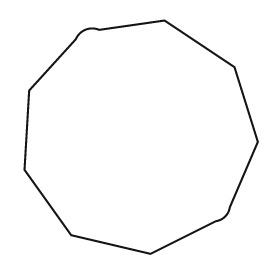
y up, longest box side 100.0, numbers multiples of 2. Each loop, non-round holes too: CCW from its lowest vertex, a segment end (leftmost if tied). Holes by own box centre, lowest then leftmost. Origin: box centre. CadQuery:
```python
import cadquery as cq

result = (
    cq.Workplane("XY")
    .moveTo(4.0, -50.0)
    .lineTo(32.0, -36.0)
    .threePointArc((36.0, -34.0), (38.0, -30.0))
    .lineTo(50.0, -2.0)
    .lineTo(40.0, 30.0)
    .lineTo(10.0, 50.0)
    .lineTo(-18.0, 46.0)
    .threePointArc((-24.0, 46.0), (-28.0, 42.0))
    .lineTo(-48.0, 20.0)
    .lineTo(-50.0, -14.0)
    .lineTo(-30.0, -42.0)
    .close()
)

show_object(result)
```